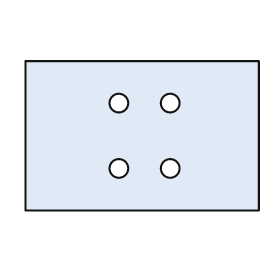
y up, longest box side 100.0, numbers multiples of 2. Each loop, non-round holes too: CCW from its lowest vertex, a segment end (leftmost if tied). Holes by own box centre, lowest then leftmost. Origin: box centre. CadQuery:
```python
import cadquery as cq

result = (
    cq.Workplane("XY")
    .moveTo(-50.0, -32.0)
    .lineTo(50.0, -32.0)
    .lineTo(50.0, 32.0)
    .lineTo(-50.0, 32.0)
    .close()
    .moveTo(-10.0, -14.0)
    .circle(4.0)
    .moveTo(12.0, -14.0)
    .circle(4.0)
    .moveTo(-10.0, 14.0)
    .circle(4.0)
    .moveTo(12.0, 14.0)
    .circle(4.0)
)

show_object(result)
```